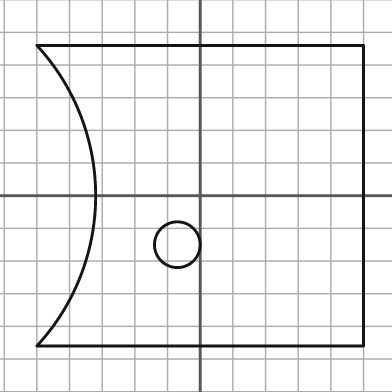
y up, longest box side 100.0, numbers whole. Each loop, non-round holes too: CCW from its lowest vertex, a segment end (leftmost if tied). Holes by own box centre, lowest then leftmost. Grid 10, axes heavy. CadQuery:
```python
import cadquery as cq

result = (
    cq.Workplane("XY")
    .moveTo(-50.0, -46.0)
    .lineTo(50.0, -46.0)
    .lineTo(50.0, 46.0)
    .lineTo(-50.0, 46.0)
    .threePointArc((-32.0, 0.0), (-50.0, -46.0))
    .close()
    .moveTo(-7.0, -15.0)
    .circle(7.0)
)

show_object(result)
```